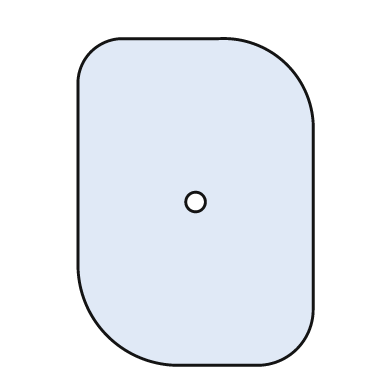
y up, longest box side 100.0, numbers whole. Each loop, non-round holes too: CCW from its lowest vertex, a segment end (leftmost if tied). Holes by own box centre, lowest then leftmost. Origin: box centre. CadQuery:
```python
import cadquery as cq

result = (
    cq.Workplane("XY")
    .moveTo(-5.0, -50.0)
    .lineTo(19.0, -50.0)
    .threePointArc((31.0, -45.0), (36.0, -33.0))
    .lineTo(36.0, 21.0)
    .threePointArc((28.0, 42.0), (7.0, 50.0))
    .lineTo(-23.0, 50.0)
    .threePointArc((-32.0, 46.0), (-36.0, 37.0))
    .lineTo(-36.0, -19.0)
    .threePointArc((-27.0, -41.0), (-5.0, -50.0))
    .close()
    .moveTo(0.0, 0.0)
    .circle(3.0)
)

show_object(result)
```